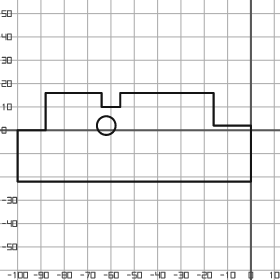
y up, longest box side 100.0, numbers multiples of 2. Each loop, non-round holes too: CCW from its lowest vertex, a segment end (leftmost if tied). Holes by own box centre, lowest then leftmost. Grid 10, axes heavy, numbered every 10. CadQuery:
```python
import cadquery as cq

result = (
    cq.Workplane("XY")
    .moveTo(-100.0, -22.0)
    .lineTo(0.0, -22.0)
    .lineTo(0.0, 2.0)
    .lineTo(-16.0, 2.0)
    .lineTo(-16.0, 16.0)
    .lineTo(-56.0, 16.0)
    .lineTo(-56.0, 10.0)
    .lineTo(-64.0, 10.0)
    .lineTo(-64.0, 16.0)
    .lineTo(-88.0, 16.0)
    .lineTo(-88.0, 0.0)
    .lineTo(-100.0, 0.0)
    .close()
    .moveTo(-62.0, 2.0)
    .circle(4.0)
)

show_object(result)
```